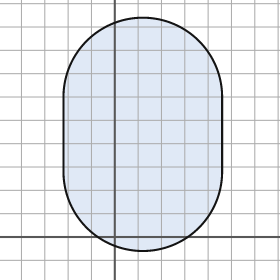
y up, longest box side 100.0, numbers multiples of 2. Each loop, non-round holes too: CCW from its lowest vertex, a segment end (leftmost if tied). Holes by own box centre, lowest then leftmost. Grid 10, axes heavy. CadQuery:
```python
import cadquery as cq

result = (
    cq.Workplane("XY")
    .moveTo(-22.0, 28.0)
    .threePointArc((12.0, -6.0), (46.0, 28.0))
    .lineTo(46.0, 60.0)
    .threePointArc((12.0, 94.0), (-22.0, 60.0))
    .close()
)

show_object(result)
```